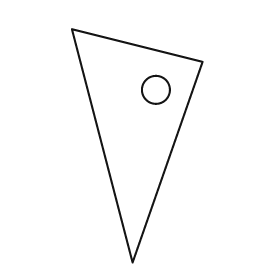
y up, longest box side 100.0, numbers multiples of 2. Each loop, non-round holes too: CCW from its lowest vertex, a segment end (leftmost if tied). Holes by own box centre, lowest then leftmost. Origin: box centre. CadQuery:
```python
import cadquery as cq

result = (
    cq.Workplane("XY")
    .moveTo(-2.0, -50.0)
    .lineTo(28.0, 36.0)
    .lineTo(-28.0, 50.0)
    .close()
    .moveTo(8.0, 24.0)
    .circle(6.0)
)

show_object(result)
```